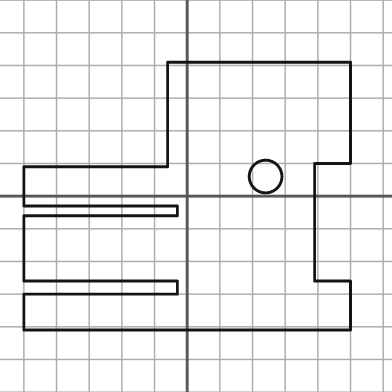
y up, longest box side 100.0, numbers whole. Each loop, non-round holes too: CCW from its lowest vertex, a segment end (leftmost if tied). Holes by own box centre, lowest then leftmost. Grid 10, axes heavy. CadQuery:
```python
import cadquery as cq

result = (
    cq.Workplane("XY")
    .moveTo(-50.0, -41.0)
    .lineTo(50.0, -41.0)
    .lineTo(50.0, -26.0)
    .lineTo(39.0, -26.0)
    .lineTo(39.0, 10.0)
    .lineTo(50.0, 10.0)
    .lineTo(50.0, 41.0)
    .lineTo(-6.0, 41.0)
    .lineTo(-6.0, 9.0)
    .lineTo(-50.0, 9.0)
    .lineTo(-50.0, -3.0)
    .lineTo(-3.0, -3.0)
    .lineTo(-3.0, -6.0)
    .lineTo(-50.0, -6.0)
    .lineTo(-50.0, -26.0)
    .lineTo(-3.0, -26.0)
    .lineTo(-3.0, -30.0)
    .lineTo(-50.0, -30.0)
    .close()
    .moveTo(24.0, 6.0)
    .circle(5.0)
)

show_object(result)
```